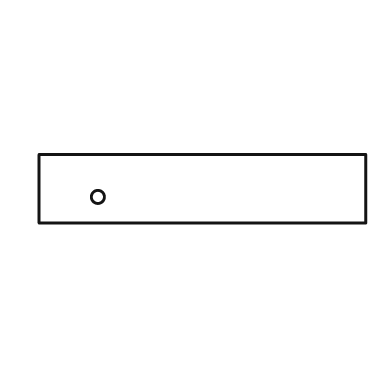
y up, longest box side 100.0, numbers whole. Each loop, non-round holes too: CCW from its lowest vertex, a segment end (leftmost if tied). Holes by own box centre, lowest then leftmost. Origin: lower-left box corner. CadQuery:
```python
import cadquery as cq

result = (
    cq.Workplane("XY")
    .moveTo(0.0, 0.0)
    .lineTo(100.0, 0.0)
    .lineTo(100.0, 21.0)
    .lineTo(0.0, 21.0)
    .close()
    .moveTo(18.0, 8.0)
    .circle(2.0)
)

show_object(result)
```